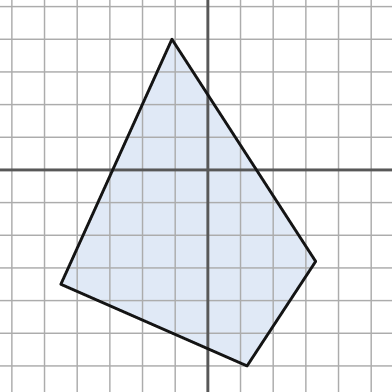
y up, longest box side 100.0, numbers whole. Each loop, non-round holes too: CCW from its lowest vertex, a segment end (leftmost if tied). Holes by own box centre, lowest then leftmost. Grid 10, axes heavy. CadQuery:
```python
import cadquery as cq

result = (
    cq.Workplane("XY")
    .moveTo(12.0, -60.0)
    .lineTo(33.0, -28.0)
    .lineTo(-11.0, 40.0)
    .lineTo(-45.0, -35.0)
    .close()
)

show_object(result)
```